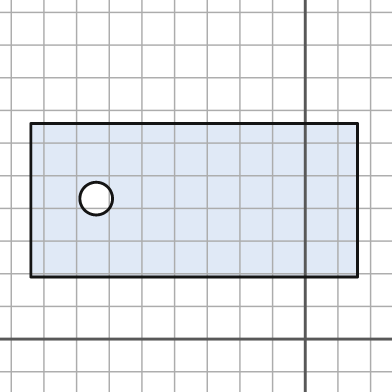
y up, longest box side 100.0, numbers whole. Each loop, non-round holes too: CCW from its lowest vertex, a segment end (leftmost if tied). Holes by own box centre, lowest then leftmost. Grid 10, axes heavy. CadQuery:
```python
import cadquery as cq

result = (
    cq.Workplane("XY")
    .moveTo(-84.0, 19.0)
    .lineTo(16.0, 19.0)
    .lineTo(16.0, 66.0)
    .lineTo(-84.0, 66.0)
    .close()
    .moveTo(-64.0, 43.0)
    .circle(5.0)
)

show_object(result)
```